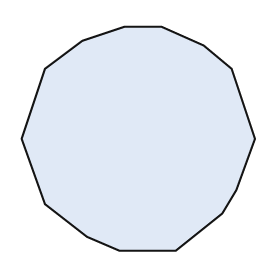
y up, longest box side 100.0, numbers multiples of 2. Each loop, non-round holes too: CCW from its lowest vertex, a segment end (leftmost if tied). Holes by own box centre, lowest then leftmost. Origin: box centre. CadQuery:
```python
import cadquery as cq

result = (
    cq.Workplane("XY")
    .moveTo(-8.0, -48.0)
    .lineTo(16.0, -48.0)
    .lineTo(36.0, -32.0)
    .lineTo(42.0, -22.0)
    .lineTo(50.0, 0.0)
    .lineTo(40.0, 30.0)
    .lineTo(28.0, 40.0)
    .lineTo(10.0, 48.0)
    .lineTo(-6.0, 48.0)
    .lineTo(-24.0, 42.0)
    .lineTo(-40.0, 30.0)
    .lineTo(-50.0, 0.0)
    .lineTo(-40.0, -28.0)
    .lineTo(-22.0, -42.0)
    .close()
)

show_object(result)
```